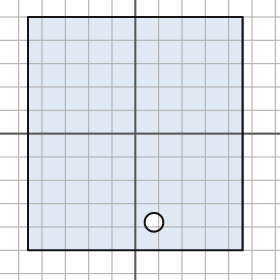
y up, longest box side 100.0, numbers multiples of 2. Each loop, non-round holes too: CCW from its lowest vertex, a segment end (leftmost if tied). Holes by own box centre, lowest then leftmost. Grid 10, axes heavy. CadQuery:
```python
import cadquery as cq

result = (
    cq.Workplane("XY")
    .moveTo(-46.0, -50.0)
    .lineTo(46.0, -50.0)
    .lineTo(46.0, 50.0)
    .lineTo(-46.0, 50.0)
    .close()
    .moveTo(8.0, -38.0)
    .circle(4.0)
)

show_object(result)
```